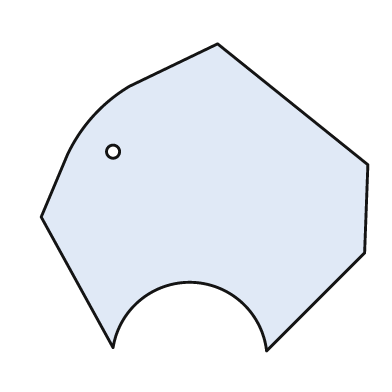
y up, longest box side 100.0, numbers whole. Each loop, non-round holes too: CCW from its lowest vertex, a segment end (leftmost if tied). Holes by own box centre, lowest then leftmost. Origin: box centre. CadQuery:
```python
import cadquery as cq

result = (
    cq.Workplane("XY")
    .moveTo(19.0, -47.0)
    .lineTo(49.0, -17.0)
    .lineTo(50.0, 10.0)
    .lineTo(4.0, 47.0)
    .lineTo(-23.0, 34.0)
    .threePointArc((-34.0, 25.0), (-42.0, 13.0))
    .lineTo(-50.0, -6.0)
    .lineTo(-28.0, -46.0)
    .threePointArc((-4.0, -26.0), (19.0, -47.0))
    .close()
    .moveTo(-28.0, 14.0)
    .circle(2.0)
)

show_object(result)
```